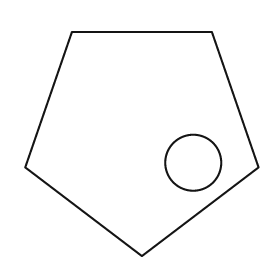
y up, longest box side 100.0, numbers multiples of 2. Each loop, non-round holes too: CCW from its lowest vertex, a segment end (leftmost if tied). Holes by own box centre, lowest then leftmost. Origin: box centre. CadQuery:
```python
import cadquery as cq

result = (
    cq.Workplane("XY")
    .moveTo(0.0, -48.0)
    .lineTo(50.0, -10.0)
    .lineTo(30.0, 48.0)
    .lineTo(-30.0, 48.0)
    .lineTo(-50.0, -10.0)
    .close()
    .moveTo(22.0, -8.0)
    .circle(12.0)
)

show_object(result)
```